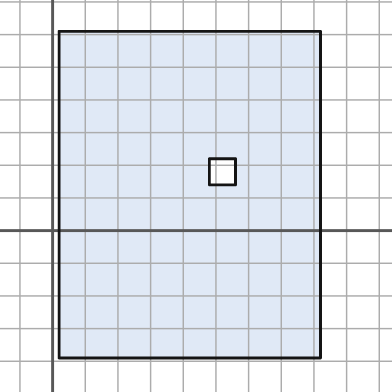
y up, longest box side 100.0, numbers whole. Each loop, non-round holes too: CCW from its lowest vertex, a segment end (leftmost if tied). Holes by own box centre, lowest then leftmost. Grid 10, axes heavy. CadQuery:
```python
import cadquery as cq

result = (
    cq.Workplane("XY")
    .moveTo(2.0, -39.0)
    .lineTo(82.0, -39.0)
    .lineTo(82.0, 61.0)
    .lineTo(2.0, 61.0)
    .close()
    .moveTo(48.0, 14.0)
    .lineTo(56.0, 14.0)
    .lineTo(56.0, 22.0)
    .lineTo(48.0, 22.0)
    .close()
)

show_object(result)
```